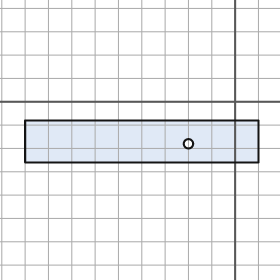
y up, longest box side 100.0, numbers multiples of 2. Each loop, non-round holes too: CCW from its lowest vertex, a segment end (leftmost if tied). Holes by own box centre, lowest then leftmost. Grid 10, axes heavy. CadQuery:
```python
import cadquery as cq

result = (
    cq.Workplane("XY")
    .moveTo(-90.0, -26.0)
    .lineTo(10.0, -26.0)
    .lineTo(10.0, -8.0)
    .lineTo(-90.0, -8.0)
    .close()
    .moveTo(-20.0, -18.0)
    .circle(2.0)
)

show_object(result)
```